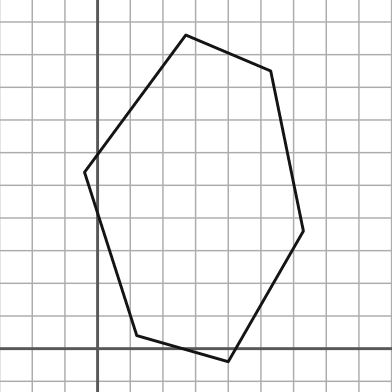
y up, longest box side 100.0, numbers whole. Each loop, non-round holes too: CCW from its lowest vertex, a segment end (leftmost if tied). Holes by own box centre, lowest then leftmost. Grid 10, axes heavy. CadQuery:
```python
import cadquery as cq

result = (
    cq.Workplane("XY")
    .moveTo(40.0, -4.0)
    .lineTo(63.0, 36.0)
    .lineTo(53.0, 85.0)
    .lineTo(27.0, 96.0)
    .lineTo(-4.0, 54.0)
    .lineTo(12.0, 4.0)
    .close()
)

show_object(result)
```